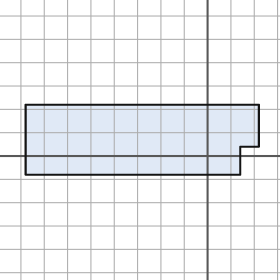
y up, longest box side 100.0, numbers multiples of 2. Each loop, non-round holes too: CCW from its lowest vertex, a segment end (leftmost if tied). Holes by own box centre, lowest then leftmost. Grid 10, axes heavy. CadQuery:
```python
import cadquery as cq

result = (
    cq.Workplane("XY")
    .moveTo(-78.0, -8.0)
    .lineTo(14.0, -8.0)
    .lineTo(14.0, 4.0)
    .lineTo(22.0, 4.0)
    .lineTo(22.0, 22.0)
    .lineTo(-78.0, 22.0)
    .close()
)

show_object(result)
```